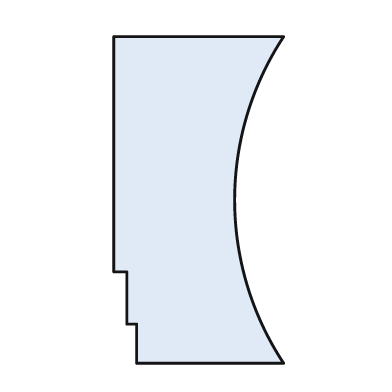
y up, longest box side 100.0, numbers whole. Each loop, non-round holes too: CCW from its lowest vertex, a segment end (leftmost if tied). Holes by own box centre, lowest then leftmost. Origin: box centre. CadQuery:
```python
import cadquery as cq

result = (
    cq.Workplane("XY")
    .moveTo(-19.0, -50.0)
    .lineTo(26.0, -50.0)
    .threePointArc((11.0, 0.0), (26.0, 50.0))
    .lineTo(-26.0, 50.0)
    .lineTo(-26.0, -22.0)
    .lineTo(-22.0, -22.0)
    .lineTo(-22.0, -38.0)
    .lineTo(-19.0, -38.0)
    .close()
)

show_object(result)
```